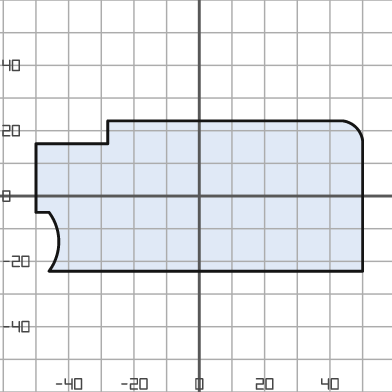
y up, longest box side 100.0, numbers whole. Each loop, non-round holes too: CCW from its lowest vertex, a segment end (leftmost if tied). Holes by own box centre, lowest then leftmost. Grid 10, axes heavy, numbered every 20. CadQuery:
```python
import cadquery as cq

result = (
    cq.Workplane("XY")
    .moveTo(-46.0, -23.0)
    .lineTo(50.0, -23.0)
    .lineTo(50.0, 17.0)
    .threePointArc((48.0, 21.0), (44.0, 23.0))
    .lineTo(-28.0, 23.0)
    .lineTo(-28.0, 16.0)
    .lineTo(-50.0, 16.0)
    .lineTo(-50.0, -5.0)
    .lineTo(-46.0, -5.0)
    .threePointArc((-43.0, -14.0), (-46.0, -23.0))
    .close()
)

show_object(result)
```